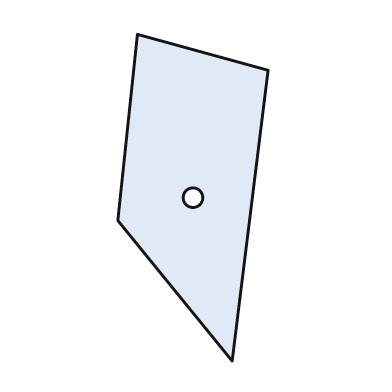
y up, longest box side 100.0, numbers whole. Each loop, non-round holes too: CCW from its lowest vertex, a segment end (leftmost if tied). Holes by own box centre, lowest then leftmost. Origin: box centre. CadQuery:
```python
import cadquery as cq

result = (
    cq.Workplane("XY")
    .moveTo(12.0, -50.0)
    .lineTo(23.0, 39.0)
    .lineTo(-17.0, 50.0)
    .lineTo(-23.0, -7.0)
    .close()
    .moveTo(0.0, 0.0)
    .circle(3.0)
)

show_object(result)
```